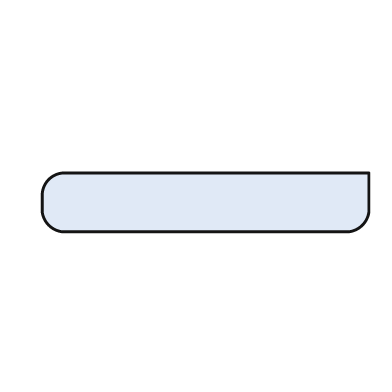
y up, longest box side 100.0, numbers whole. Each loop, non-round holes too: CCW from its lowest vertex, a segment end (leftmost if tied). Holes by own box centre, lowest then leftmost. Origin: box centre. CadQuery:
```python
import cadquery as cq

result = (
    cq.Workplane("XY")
    .moveTo(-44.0, -9.0)
    .lineTo(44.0, -9.0)
    .threePointArc((48.0, -7.0), (50.0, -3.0))
    .lineTo(50.0, 9.0)
    .lineTo(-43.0, 9.0)
    .threePointArc((-48.0, 7.0), (-50.0, 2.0))
    .lineTo(-50.0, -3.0)
    .threePointArc((-48.0, -7.0), (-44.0, -9.0))
    .close()
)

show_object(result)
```